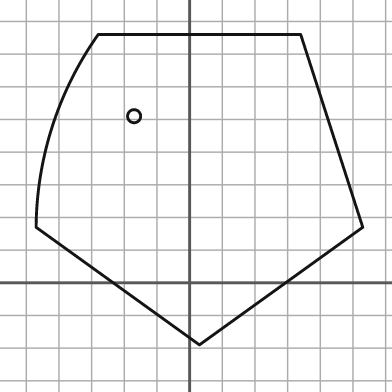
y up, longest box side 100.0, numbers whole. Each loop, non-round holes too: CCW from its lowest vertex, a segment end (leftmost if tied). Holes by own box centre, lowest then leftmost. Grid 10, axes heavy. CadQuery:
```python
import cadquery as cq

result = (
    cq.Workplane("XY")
    .moveTo(3.0, -19.0)
    .lineTo(53.0, 17.0)
    .lineTo(34.0, 76.0)
    .lineTo(-28.0, 76.0)
    .threePointArc((-42.0, 48.0), (-47.0, 17.0))
    .close()
    .moveTo(-17.0, 51.0)
    .circle(2.0)
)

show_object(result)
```